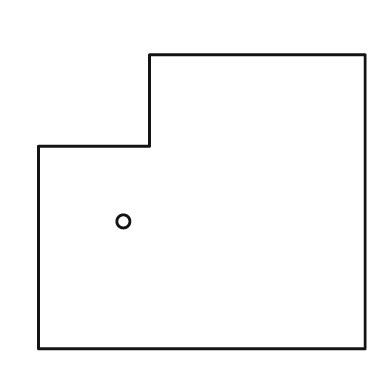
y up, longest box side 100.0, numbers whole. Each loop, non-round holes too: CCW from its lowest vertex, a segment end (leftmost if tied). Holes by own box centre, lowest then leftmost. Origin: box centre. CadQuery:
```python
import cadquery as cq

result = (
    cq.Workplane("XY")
    .moveTo(-50.0, -45.0)
    .lineTo(50.0, -45.0)
    .lineTo(50.0, 45.0)
    .lineTo(-16.0, 45.0)
    .lineTo(-16.0, 17.0)
    .lineTo(-50.0, 17.0)
    .close()
    .moveTo(-24.0, -6.0)
    .circle(2.0)
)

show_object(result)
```